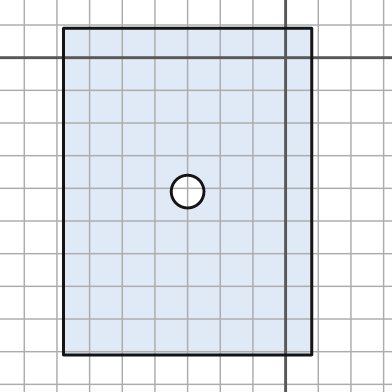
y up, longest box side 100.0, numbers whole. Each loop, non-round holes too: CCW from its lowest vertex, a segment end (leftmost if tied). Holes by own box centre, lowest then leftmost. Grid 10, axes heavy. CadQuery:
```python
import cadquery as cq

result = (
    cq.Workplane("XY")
    .moveTo(-68.0, -91.0)
    .lineTo(8.0, -91.0)
    .lineTo(8.0, 9.0)
    .lineTo(-68.0, 9.0)
    .close()
    .moveTo(-30.0, -41.0)
    .circle(5.0)
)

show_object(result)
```